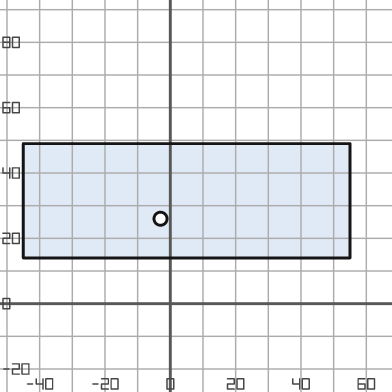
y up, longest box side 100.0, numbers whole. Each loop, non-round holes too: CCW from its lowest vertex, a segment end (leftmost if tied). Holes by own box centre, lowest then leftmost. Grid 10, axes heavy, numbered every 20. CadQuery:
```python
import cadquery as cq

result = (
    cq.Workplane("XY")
    .moveTo(-45.0, 14.0)
    .lineTo(55.0, 14.0)
    .lineTo(55.0, 49.0)
    .lineTo(-45.0, 49.0)
    .close()
    .moveTo(-3.0, 26.0)
    .circle(2.0)
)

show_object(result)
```